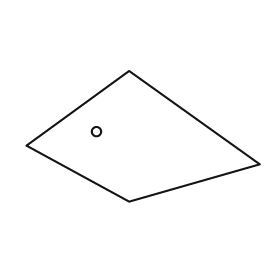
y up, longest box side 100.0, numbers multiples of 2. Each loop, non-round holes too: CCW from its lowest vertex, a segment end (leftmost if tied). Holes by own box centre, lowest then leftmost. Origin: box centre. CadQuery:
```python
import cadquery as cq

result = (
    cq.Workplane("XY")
    .moveTo(-6.0, -28.0)
    .lineTo(50.0, -12.0)
    .lineTo(-6.0, 28.0)
    .lineTo(-50.0, -4.0)
    .close()
    .moveTo(-20.0, 2.0)
    .circle(2.0)
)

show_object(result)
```